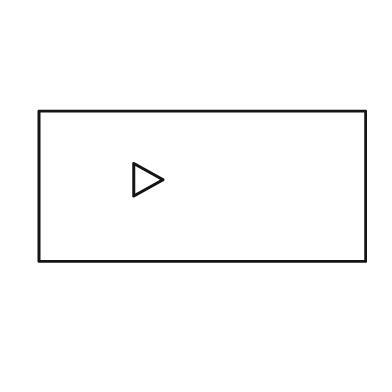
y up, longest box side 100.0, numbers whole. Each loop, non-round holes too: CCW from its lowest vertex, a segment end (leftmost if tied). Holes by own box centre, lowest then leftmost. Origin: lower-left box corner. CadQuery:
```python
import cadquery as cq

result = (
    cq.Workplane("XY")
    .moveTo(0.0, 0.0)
    .lineTo(100.0, 0.0)
    .lineTo(100.0, 46.0)
    .lineTo(0.0, 46.0)
    .close()
    .moveTo(29.0, 20.0)
    .lineTo(38.0, 25.0)
    .lineTo(29.0, 30.0)
    .close()
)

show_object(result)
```